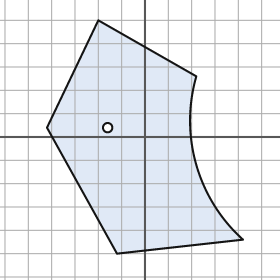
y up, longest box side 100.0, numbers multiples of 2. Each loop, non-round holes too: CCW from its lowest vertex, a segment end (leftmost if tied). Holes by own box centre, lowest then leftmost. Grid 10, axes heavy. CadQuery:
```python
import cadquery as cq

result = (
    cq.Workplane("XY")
    .moveTo(-12.0, -50.0)
    .lineTo(42.0, -44.0)
    .threePointArc((22.0, -12.0), (22.0, 26.0))
    .lineTo(-20.0, 50.0)
    .lineTo(-42.0, 4.0)
    .close()
    .moveTo(-16.0, 4.0)
    .circle(2.0)
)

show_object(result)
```